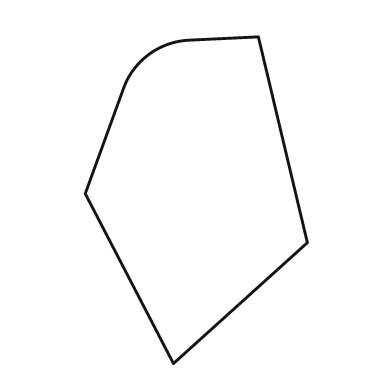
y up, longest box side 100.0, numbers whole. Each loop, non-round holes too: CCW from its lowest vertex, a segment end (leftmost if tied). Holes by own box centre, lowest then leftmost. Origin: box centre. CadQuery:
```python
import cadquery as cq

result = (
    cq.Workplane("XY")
    .moveTo(-7.0, -50.0)
    .lineTo(34.0, -13.0)
    .lineTo(19.0, 50.0)
    .lineTo(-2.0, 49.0)
    .threePointArc((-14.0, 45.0), (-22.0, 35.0))
    .lineTo(-34.0, 2.0)
    .close()
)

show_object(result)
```